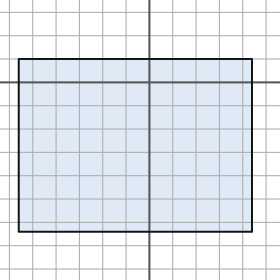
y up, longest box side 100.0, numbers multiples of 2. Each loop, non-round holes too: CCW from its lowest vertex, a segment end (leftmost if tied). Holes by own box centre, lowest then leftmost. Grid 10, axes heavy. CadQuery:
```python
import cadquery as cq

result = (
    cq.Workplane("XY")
    .moveTo(-56.0, -64.0)
    .lineTo(44.0, -64.0)
    .lineTo(44.0, 10.0)
    .lineTo(-56.0, 10.0)
    .close()
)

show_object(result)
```